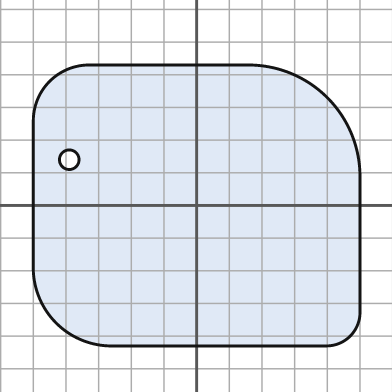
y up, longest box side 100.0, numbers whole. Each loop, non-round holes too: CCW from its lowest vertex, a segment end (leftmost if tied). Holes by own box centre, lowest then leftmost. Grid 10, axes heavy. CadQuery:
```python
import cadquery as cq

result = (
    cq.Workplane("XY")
    .moveTo(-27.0, -43.0)
    .lineTo(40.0, -43.0)
    .threePointArc((47.0, -40.0), (50.0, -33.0))
    .lineTo(50.0, 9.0)
    .threePointArc((40.0, 33.0), (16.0, 43.0))
    .lineTo(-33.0, 43.0)
    .threePointArc((-45.0, 38.0), (-50.0, 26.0))
    .lineTo(-50.0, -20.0)
    .threePointArc((-43.0, -36.0), (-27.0, -43.0))
    .close()
    .moveTo(-39.0, 14.0)
    .circle(3.0)
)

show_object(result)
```